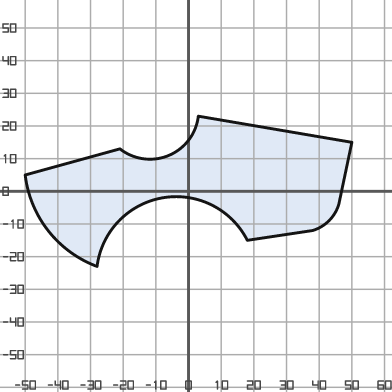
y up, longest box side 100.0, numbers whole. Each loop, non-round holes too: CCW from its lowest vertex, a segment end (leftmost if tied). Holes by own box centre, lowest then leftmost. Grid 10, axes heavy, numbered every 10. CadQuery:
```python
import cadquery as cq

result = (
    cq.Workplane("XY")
    .moveTo(-28.0, -23.0)
    .threePointArc((-8.0, -2.0), (18.0, -15.0))
    .lineTo(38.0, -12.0)
    .threePointArc((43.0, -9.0), (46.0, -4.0))
    .lineTo(50.0, 15.0)
    .lineTo(3.0, 23.0)
    .threePointArc((-6.0, 11.0), (-21.0, 13.0))
    .lineTo(-50.0, 5.0)
    .threePointArc((-43.0, -12.0), (-28.0, -23.0))
    .close()
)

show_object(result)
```